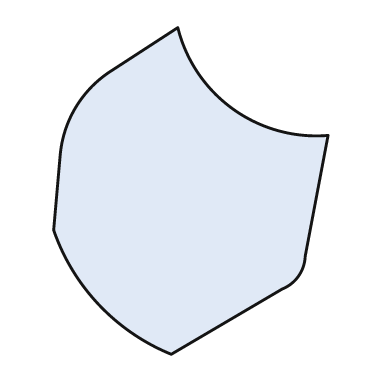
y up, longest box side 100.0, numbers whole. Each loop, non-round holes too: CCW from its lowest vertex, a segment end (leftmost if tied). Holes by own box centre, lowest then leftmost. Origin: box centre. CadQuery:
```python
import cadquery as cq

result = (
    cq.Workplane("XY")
    .moveTo(-6.0, -50.0)
    .lineTo(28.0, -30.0)
    .threePointArc((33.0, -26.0), (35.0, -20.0))
    .lineTo(42.0, 17.0)
    .threePointArc((13.0, 25.0), (-4.0, 50.0))
    .lineTo(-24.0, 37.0)
    .threePointArc((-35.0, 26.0), (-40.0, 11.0))
    .lineTo(-42.0, -12.0)
    .threePointArc((-28.0, -35.0), (-6.0, -50.0))
    .close()
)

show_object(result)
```